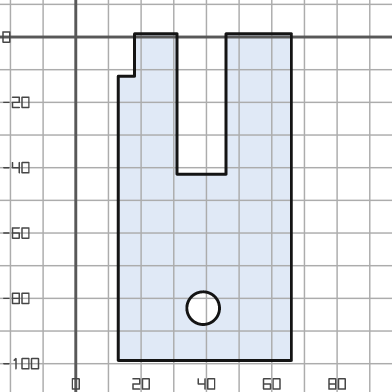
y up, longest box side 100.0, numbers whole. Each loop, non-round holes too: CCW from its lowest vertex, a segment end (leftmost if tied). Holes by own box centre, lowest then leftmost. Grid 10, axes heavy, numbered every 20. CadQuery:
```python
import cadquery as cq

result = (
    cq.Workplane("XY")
    .moveTo(13.0, -99.0)
    .lineTo(66.0, -99.0)
    .lineTo(66.0, 1.0)
    .lineTo(46.0, 1.0)
    .lineTo(46.0, -42.0)
    .lineTo(31.0, -42.0)
    .lineTo(31.0, 1.0)
    .lineTo(18.0, 1.0)
    .lineTo(18.0, -12.0)
    .lineTo(13.0, -12.0)
    .close()
    .moveTo(39.0, -83.0)
    .circle(5.0)
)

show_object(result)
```